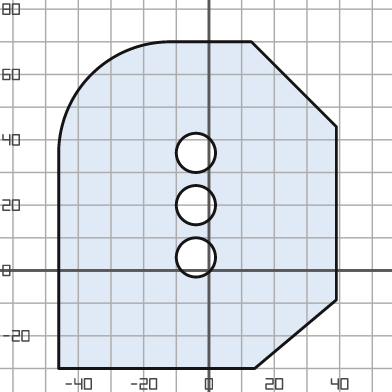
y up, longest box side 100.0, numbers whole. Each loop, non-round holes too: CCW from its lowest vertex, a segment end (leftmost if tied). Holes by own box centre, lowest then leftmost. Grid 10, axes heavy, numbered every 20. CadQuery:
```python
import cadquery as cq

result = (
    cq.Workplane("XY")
    .moveTo(-46.0, -30.0)
    .lineTo(14.0, -30.0)
    .lineTo(39.0, -9.0)
    .lineTo(39.0, 44.0)
    .lineTo(13.0, 70.0)
    .lineTo(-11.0, 70.0)
    .threePointArc((-36.0, 60.0), (-46.0, 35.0))
    .close()
    .moveTo(-4.0, 4.0)
    .circle(6.0)
    .moveTo(-4.0, 20.0)
    .circle(6.0)
    .moveTo(-4.0, 36.0)
    .circle(6.0)
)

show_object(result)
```